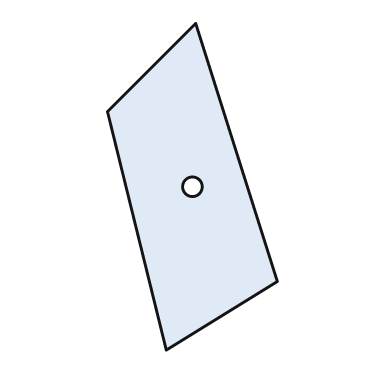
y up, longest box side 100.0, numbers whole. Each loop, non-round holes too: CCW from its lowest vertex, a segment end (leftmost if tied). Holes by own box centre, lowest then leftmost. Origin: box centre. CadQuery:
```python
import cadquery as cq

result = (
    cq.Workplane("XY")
    .moveTo(-8.0, -50.0)
    .lineTo(26.0, -29.0)
    .lineTo(1.0, 50.0)
    .lineTo(-26.0, 23.0)
    .close()
    .moveTo(0.0, 0.0)
    .circle(3.0)
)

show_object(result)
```